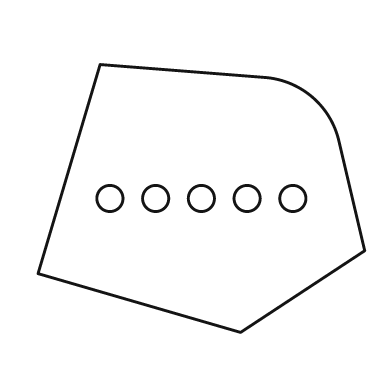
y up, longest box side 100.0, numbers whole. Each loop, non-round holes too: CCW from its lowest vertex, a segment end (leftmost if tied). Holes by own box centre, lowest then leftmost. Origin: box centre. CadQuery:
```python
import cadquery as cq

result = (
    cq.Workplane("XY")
    .moveTo(12.0, -41.0)
    .lineTo(50.0, -16.0)
    .lineTo(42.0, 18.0)
    .threePointArc((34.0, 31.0), (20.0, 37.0))
    .lineTo(-31.0, 41.0)
    .lineTo(-50.0, -23.0)
    .close()
    .moveTo(-28.0, 0.0)
    .circle(4.0)
    .moveTo(-14.0, 0.0)
    .circle(4.0)
    .moveTo(0.0, 0.0)
    .circle(4.0)
    .moveTo(14.0, 0.0)
    .circle(4.0)
    .moveTo(28.0, 0.0)
    .circle(4.0)
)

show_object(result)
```